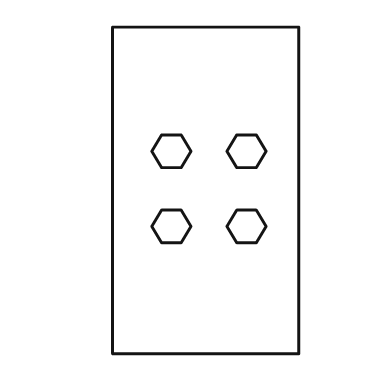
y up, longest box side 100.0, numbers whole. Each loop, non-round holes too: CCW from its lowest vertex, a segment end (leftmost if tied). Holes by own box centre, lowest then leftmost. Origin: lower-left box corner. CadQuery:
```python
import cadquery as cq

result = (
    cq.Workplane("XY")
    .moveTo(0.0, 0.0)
    .lineTo(57.0, 0.0)
    .lineTo(57.0, 100.0)
    .lineTo(0.0, 100.0)
    .close()
    .moveTo(15.0, 34.0)
    .lineTo(21.0, 34.0)
    .lineTo(24.0, 39.0)
    .lineTo(21.0, 44.0)
    .lineTo(15.0, 44.0)
    .lineTo(12.0, 39.0)
    .close()
    .moveTo(38.0, 34.0)
    .lineTo(44.0, 34.0)
    .lineTo(47.0, 39.0)
    .lineTo(44.0, 44.0)
    .lineTo(38.0, 44.0)
    .lineTo(35.0, 39.0)
    .close()
    .moveTo(15.0, 57.0)
    .lineTo(21.0, 57.0)
    .lineTo(24.0, 62.0)
    .lineTo(21.0, 67.0)
    .lineTo(15.0, 67.0)
    .lineTo(12.0, 62.0)
    .close()
    .moveTo(38.0, 57.0)
    .lineTo(44.0, 57.0)
    .lineTo(47.0, 62.0)
    .lineTo(44.0, 67.0)
    .lineTo(38.0, 67.0)
    .lineTo(35.0, 62.0)
    .close()
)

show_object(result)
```